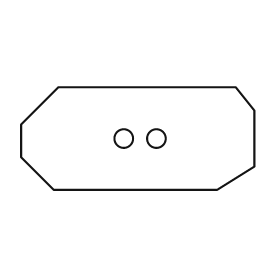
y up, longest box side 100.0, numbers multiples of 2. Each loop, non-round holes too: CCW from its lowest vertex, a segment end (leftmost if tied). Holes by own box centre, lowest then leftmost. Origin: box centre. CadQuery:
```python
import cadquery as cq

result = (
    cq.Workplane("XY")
    .moveTo(-36.0, -22.0)
    .lineTo(34.0, -22.0)
    .lineTo(50.0, -12.0)
    .lineTo(50.0, 12.0)
    .lineTo(42.0, 22.0)
    .lineTo(-34.0, 22.0)
    .lineTo(-50.0, 6.0)
    .lineTo(-50.0, -8.0)
    .close()
    .moveTo(-6.0, 0.0)
    .circle(4.0)
    .moveTo(8.0, 0.0)
    .circle(4.0)
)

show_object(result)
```